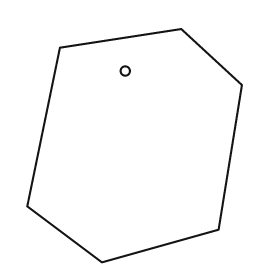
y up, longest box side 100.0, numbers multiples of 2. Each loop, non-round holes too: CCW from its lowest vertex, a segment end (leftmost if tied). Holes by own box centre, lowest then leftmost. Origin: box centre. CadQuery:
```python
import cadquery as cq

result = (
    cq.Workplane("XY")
    .moveTo(-14.0, -50.0)
    .lineTo(36.0, -36.0)
    .lineTo(46.0, 26.0)
    .lineTo(20.0, 50.0)
    .lineTo(-32.0, 42.0)
    .lineTo(-46.0, -26.0)
    .close()
    .moveTo(-4.0, 32.0)
    .circle(2.0)
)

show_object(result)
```